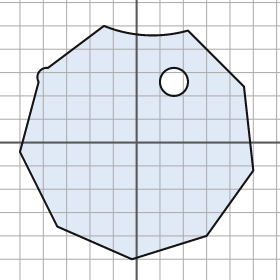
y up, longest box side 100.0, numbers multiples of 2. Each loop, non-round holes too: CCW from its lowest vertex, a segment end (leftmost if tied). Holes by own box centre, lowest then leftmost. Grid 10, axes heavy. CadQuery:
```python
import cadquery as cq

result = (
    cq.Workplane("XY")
    .moveTo(-2.0, -50.0)
    .lineTo(30.0, -40.0)
    .lineTo(50.0, -12.0)
    .lineTo(46.0, 24.0)
    .lineTo(22.0, 48.0)
    .threePointArc((4.0, 46.0), (-14.0, 50.0))
    .lineTo(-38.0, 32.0)
    .threePointArc((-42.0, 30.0), (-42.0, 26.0))
    .lineTo(-50.0, -4.0)
    .lineTo(-34.0, -36.0)
    .close()
    .moveTo(16.0, 26.0)
    .circle(6.0)
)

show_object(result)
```